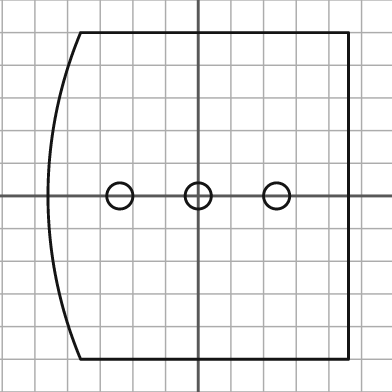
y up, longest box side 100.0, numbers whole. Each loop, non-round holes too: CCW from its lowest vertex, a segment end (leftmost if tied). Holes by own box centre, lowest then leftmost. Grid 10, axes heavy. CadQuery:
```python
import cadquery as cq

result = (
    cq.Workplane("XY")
    .moveTo(-36.0, -50.0)
    .lineTo(46.0, -50.0)
    .lineTo(46.0, 50.0)
    .lineTo(-36.0, 50.0)
    .threePointArc((-46.0, 0.0), (-36.0, -50.0))
    .close()
    .moveTo(-24.0, 0.0)
    .circle(4.0)
    .moveTo(0.0, 0.0)
    .circle(4.0)
    .moveTo(24.0, 0.0)
    .circle(4.0)
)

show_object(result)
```